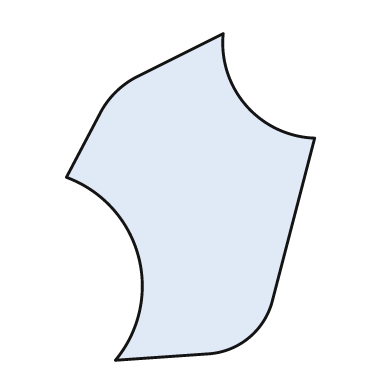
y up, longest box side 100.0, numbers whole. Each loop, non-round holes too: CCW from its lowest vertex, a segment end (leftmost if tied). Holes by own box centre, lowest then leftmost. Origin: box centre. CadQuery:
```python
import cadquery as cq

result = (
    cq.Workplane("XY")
    .moveTo(-23.0, -50.0)
    .lineTo(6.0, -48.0)
    .threePointArc((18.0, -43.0), (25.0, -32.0))
    .lineTo(38.0, 18.0)
    .threePointArc((17.0, 28.0), (10.0, 50.0))
    .lineTo(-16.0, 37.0)
    .threePointArc((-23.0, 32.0), (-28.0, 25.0))
    .lineTo(-38.0, 6.0)
    .threePointArc((-16.0, -18.0), (-23.0, -50.0))
    .close()
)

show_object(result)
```